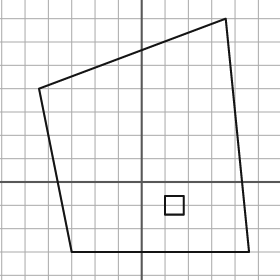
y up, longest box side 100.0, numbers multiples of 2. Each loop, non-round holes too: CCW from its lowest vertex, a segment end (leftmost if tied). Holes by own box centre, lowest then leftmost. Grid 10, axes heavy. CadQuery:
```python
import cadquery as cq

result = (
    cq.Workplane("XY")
    .moveTo(-30.0, -30.0)
    .lineTo(46.0, -30.0)
    .lineTo(36.0, 70.0)
    .lineTo(-44.0, 40.0)
    .close()
    .moveTo(10.0, -14.0)
    .lineTo(18.0, -14.0)
    .lineTo(18.0, -6.0)
    .lineTo(10.0, -6.0)
    .close()
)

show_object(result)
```